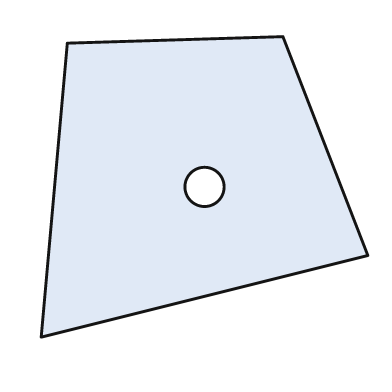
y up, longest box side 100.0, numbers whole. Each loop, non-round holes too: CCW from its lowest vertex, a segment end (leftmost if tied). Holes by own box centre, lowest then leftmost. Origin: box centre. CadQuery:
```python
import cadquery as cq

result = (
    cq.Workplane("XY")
    .moveTo(-50.0, -46.0)
    .lineTo(50.0, -21.0)
    .lineTo(24.0, 46.0)
    .lineTo(-42.0, 44.0)
    .close()
    .moveTo(0.0, 0.0)
    .circle(6.0)
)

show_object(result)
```